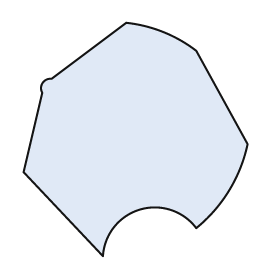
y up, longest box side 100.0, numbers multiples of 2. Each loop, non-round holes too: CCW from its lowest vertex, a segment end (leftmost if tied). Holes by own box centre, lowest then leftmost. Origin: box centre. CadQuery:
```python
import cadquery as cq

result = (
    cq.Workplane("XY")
    .moveTo(-14.0, -50.0)
    .threePointArc((2.0, -30.0), (26.0, -38.0))
    .threePointArc((40.0, -22.0), (48.0, -2.0))
    .lineTo(26.0, 38.0)
    .threePointArc((12.0, 46.0), (-4.0, 50.0))
    .lineTo(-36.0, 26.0)
    .threePointArc((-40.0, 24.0), (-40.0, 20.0))
    .lineTo(-48.0, -14.0)
    .close()
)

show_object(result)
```